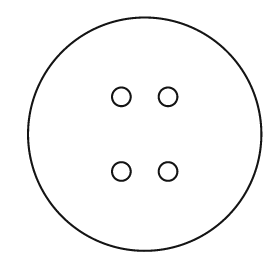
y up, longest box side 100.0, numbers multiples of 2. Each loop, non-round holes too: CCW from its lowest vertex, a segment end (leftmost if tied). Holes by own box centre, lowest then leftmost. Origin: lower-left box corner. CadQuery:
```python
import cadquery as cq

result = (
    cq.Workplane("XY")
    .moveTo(50.0, 50.0)
    .circle(50.0)
    .moveTo(40.0, 34.0)
    .circle(4.0)
    .moveTo(60.0, 34.0)
    .circle(4.0)
    .moveTo(40.0, 66.0)
    .circle(4.0)
    .moveTo(60.0, 66.0)
    .circle(4.0)
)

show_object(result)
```